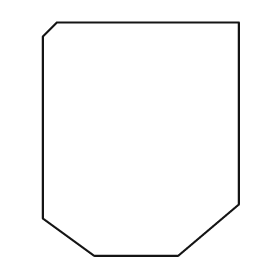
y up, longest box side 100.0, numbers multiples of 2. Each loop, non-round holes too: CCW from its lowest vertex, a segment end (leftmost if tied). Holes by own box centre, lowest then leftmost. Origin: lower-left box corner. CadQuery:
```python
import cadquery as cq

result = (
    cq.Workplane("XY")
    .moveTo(22.0, 0.0)
    .lineTo(58.0, 0.0)
    .lineTo(84.0, 22.0)
    .lineTo(84.0, 100.0)
    .lineTo(6.0, 100.0)
    .lineTo(0.0, 94.0)
    .lineTo(0.0, 16.0)
    .close()
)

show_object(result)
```